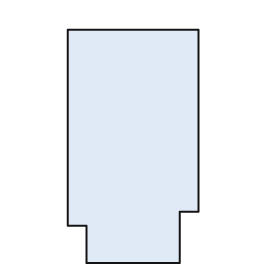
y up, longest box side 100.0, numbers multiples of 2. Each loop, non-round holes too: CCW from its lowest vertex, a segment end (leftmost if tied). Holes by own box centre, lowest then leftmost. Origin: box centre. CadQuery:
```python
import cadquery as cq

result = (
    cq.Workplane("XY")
    .moveTo(-20.0, -50.0)
    .lineTo(20.0, -50.0)
    .lineTo(20.0, -28.0)
    .lineTo(28.0, -28.0)
    .lineTo(28.0, 50.0)
    .lineTo(-28.0, 50.0)
    .lineTo(-28.0, -34.0)
    .lineTo(-20.0, -34.0)
    .close()
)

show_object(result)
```